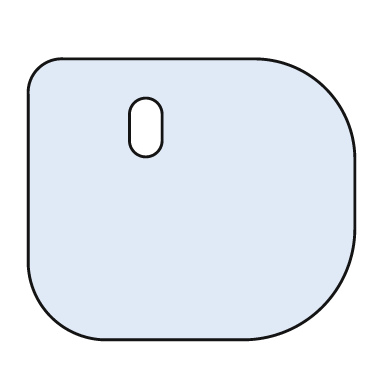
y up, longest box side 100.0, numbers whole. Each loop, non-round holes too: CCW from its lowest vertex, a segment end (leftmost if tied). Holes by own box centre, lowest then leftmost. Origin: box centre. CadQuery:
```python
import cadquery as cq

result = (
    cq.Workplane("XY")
    .moveTo(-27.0, -43.0)
    .lineTo(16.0, -43.0)
    .threePointArc((40.0, -33.0), (50.0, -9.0))
    .lineTo(50.0, 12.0)
    .threePointArc((41.0, 34.0), (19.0, 43.0))
    .lineTo(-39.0, 43.0)
    .threePointArc((-47.0, 40.0), (-50.0, 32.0))
    .lineTo(-50.0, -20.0)
    .threePointArc((-43.0, -36.0), (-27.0, -43.0))
    .close()
    .moveTo(-19.0, 18.0)
    .threePointArc((-14.0, 13.0), (-9.0, 18.0))
    .lineTo(-9.0, 26.0)
    .threePointArc((-14.0, 31.0), (-19.0, 26.0))
    .close()
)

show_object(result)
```